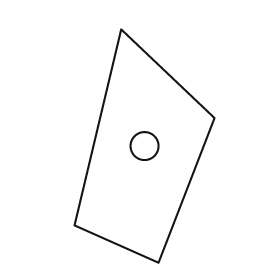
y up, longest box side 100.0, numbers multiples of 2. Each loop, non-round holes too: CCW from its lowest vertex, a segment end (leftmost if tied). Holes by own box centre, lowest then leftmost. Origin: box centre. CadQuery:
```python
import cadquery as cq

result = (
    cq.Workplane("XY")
    .moveTo(6.0, -50.0)
    .lineTo(30.0, 12.0)
    .lineTo(-10.0, 50.0)
    .lineTo(-30.0, -34.0)
    .close()
    .moveTo(0.0, 0.0)
    .circle(6.0)
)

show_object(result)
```